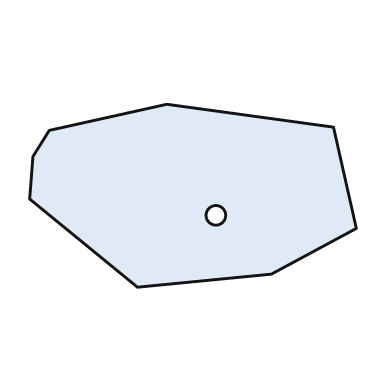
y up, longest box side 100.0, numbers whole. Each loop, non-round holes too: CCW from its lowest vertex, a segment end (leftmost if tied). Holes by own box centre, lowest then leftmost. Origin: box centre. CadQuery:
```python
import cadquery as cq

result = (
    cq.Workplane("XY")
    .moveTo(-17.0, -28.0)
    .lineTo(24.0, -24.0)
    .lineTo(50.0, -10.0)
    .lineTo(43.0, 21.0)
    .lineTo(-8.0, 28.0)
    .lineTo(-44.0, 20.0)
    .lineTo(-49.0, 12.0)
    .lineTo(-50.0, -1.0)
    .close()
    .moveTo(7.0, -6.0)
    .circle(3.0)
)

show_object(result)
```